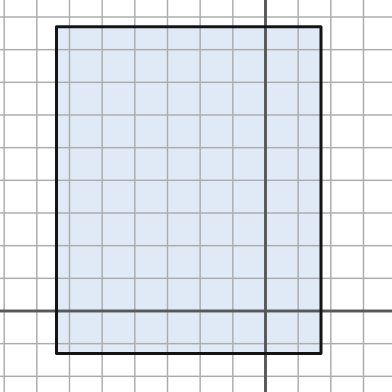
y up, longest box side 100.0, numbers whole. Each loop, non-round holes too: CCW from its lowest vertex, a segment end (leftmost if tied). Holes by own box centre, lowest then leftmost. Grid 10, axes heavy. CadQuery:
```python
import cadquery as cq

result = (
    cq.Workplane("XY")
    .moveTo(-64.0, -13.0)
    .lineTo(17.0, -13.0)
    .lineTo(17.0, 87.0)
    .lineTo(-64.0, 87.0)
    .close()
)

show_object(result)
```